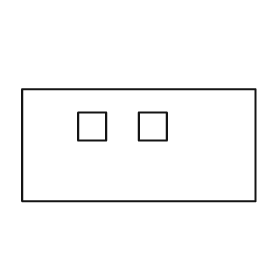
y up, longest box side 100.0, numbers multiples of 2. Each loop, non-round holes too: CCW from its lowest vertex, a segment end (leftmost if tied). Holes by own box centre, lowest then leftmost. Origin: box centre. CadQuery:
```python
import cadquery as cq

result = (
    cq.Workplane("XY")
    .moveTo(-50.0, -24.0)
    .lineTo(50.0, -24.0)
    .lineTo(50.0, 24.0)
    .lineTo(-50.0, 24.0)
    .close()
    .moveTo(-26.0, 2.0)
    .lineTo(-14.0, 2.0)
    .lineTo(-14.0, 14.0)
    .lineTo(-26.0, 14.0)
    .close()
    .moveTo(0.0, 2.0)
    .lineTo(12.0, 2.0)
    .lineTo(12.0, 14.0)
    .lineTo(0.0, 14.0)
    .close()
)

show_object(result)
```